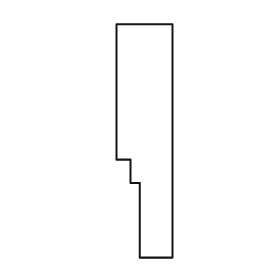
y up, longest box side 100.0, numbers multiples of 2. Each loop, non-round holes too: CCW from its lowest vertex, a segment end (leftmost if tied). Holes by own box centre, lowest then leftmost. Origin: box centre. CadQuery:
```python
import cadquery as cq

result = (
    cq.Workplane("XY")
    .moveTo(-2.0, -50.0)
    .lineTo(12.0, -50.0)
    .lineTo(12.0, 50.0)
    .lineTo(-12.0, 50.0)
    .lineTo(-12.0, -8.0)
    .lineTo(-6.0, -8.0)
    .lineTo(-6.0, -18.0)
    .lineTo(-2.0, -18.0)
    .close()
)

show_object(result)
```